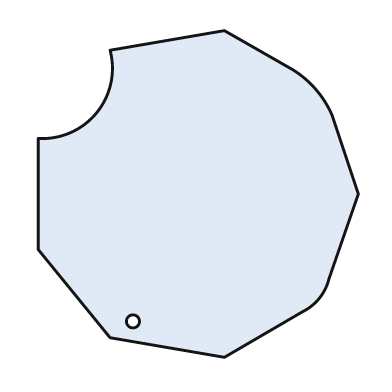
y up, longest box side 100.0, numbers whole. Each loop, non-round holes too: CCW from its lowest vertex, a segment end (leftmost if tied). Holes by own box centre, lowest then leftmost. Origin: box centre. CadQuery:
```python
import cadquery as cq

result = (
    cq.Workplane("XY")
    .moveTo(8.0, -50.0)
    .lineTo(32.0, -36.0)
    .threePointArc((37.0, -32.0), (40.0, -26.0))
    .lineTo(49.0, 0.0)
    .lineTo(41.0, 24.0)
    .threePointArc((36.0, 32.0), (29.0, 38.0))
    .lineTo(8.0, 50.0)
    .lineTo(-27.0, 44.0)
    .threePointArc((-31.0, 25.0), (-49.0, 17.0))
    .lineTo(-49.0, -17.0)
    .lineTo(-27.0, -44.0)
    .close()
    .moveTo(-20.0, -39.0)
    .circle(2.0)
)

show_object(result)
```